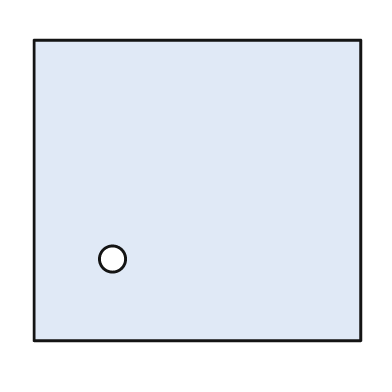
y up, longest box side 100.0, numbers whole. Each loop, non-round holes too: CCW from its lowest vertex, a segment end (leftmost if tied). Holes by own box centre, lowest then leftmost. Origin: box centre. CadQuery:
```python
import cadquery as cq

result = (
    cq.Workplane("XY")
    .moveTo(-50.0, -46.0)
    .lineTo(50.0, -46.0)
    .lineTo(50.0, 46.0)
    .lineTo(-50.0, 46.0)
    .close()
    .moveTo(-26.0, -21.0)
    .circle(4.0)
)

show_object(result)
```